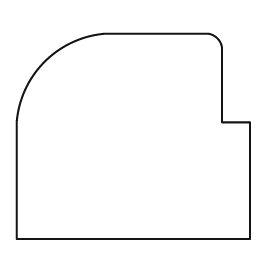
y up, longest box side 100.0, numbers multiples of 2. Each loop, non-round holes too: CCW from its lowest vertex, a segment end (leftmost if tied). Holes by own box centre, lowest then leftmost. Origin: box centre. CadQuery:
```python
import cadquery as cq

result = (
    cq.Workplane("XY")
    .moveTo(-50.0, -44.0)
    .lineTo(50.0, -44.0)
    .lineTo(50.0, 6.0)
    .lineTo(38.0, 6.0)
    .lineTo(38.0, 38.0)
    .threePointArc((36.0, 42.0), (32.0, 44.0))
    .lineTo(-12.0, 44.0)
    .threePointArc((-38.0, 32.0), (-50.0, 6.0))
    .close()
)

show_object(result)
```